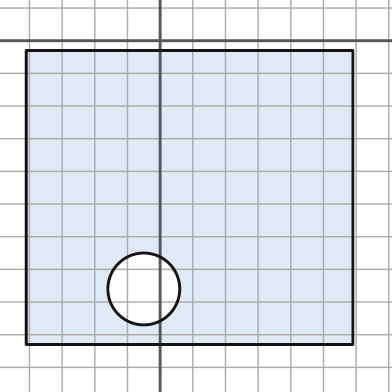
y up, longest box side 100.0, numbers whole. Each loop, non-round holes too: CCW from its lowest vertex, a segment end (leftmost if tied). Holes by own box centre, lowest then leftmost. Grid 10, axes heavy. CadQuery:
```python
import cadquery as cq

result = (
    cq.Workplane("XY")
    .moveTo(-41.0, -93.0)
    .lineTo(59.0, -93.0)
    .lineTo(59.0, -3.0)
    .lineTo(-41.0, -3.0)
    .close()
    .moveTo(-5.0, -76.0)
    .circle(11.0)
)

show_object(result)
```